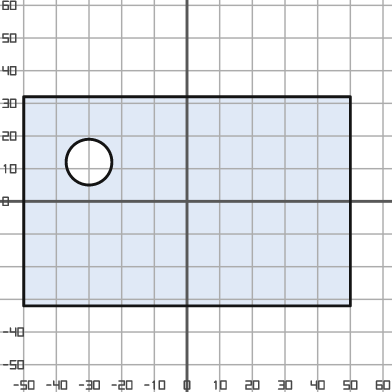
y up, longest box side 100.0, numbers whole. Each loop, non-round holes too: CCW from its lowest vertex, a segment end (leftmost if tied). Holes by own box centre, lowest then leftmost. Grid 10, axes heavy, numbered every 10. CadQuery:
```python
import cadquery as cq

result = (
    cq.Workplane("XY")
    .moveTo(-50.0, -32.0)
    .lineTo(50.0, -32.0)
    .lineTo(50.0, 32.0)
    .lineTo(-50.0, 32.0)
    .close()
    .moveTo(-30.0, 12.0)
    .circle(7.0)
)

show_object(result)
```